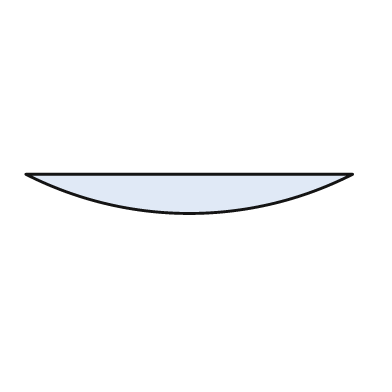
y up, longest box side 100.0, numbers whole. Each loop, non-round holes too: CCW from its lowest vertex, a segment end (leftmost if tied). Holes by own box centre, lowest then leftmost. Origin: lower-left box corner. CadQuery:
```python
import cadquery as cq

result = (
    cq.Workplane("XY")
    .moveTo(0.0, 12.0)
    .threePointArc((50.0, 0.0), (100.0, 12.0))
    .close()
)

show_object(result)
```